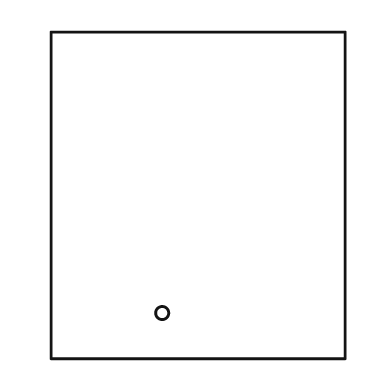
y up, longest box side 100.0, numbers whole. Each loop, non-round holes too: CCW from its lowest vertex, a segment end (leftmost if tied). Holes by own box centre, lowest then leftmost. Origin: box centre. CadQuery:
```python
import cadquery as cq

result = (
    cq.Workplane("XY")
    .moveTo(-45.0, -50.0)
    .lineTo(45.0, -50.0)
    .lineTo(45.0, 50.0)
    .lineTo(-45.0, 50.0)
    .close()
    .moveTo(-11.0, -36.0)
    .circle(2.0)
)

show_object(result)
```